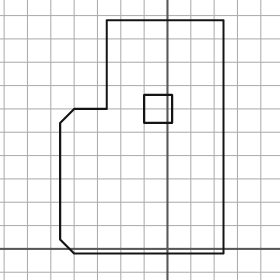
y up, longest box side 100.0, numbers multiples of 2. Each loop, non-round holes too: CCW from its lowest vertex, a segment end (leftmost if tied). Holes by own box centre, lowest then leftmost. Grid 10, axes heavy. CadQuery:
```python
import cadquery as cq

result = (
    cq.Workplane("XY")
    .moveTo(-40.0, -2.0)
    .lineTo(24.0, -2.0)
    .lineTo(24.0, 98.0)
    .lineTo(-26.0, 98.0)
    .lineTo(-26.0, 60.0)
    .lineTo(-40.0, 60.0)
    .lineTo(-46.0, 54.0)
    .lineTo(-46.0, 4.0)
    .close()
    .moveTo(-10.0, 54.0)
    .lineTo(2.0, 54.0)
    .lineTo(2.0, 66.0)
    .lineTo(-10.0, 66.0)
    .close()
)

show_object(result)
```